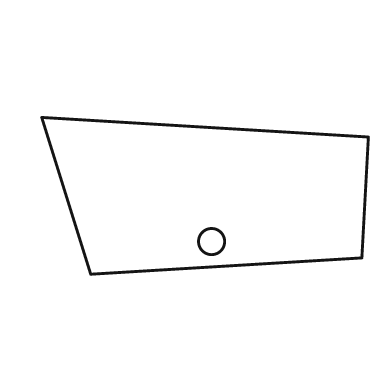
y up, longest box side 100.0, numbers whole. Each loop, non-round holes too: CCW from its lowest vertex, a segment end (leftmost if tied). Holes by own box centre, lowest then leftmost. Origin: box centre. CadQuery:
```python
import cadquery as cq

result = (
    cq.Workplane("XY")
    .moveTo(-35.0, -24.0)
    .lineTo(48.0, -19.0)
    .lineTo(50.0, 18.0)
    .lineTo(-50.0, 24.0)
    .close()
    .moveTo(2.0, -14.0)
    .circle(4.0)
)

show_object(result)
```